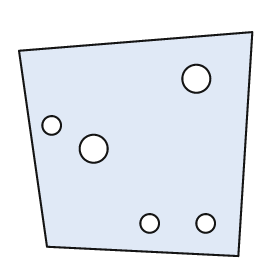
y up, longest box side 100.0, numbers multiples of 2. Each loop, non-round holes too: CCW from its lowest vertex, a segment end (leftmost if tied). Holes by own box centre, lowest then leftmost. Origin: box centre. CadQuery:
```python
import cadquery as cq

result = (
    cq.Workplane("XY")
    .moveTo(44.0, -48.0)
    .lineTo(50.0, 48.0)
    .lineTo(-50.0, 40.0)
    .lineTo(-38.0, -44.0)
    .close()
    .moveTo(6.0, -34.0)
    .circle(4.0)
    .moveTo(30.0, -34.0)
    .circle(4.0)
    .moveTo(-18.0, -2.0)
    .circle(6.0)
    .moveTo(-36.0, 8.0)
    .circle(4.0)
    .moveTo(26.0, 28.0)
    .circle(6.0)
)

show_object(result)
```